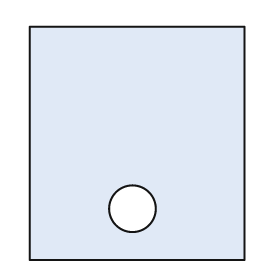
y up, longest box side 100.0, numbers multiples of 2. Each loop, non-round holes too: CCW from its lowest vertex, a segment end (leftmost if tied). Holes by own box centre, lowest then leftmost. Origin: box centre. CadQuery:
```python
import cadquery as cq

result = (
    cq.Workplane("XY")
    .moveTo(-46.0, -50.0)
    .lineTo(46.0, -50.0)
    .lineTo(46.0, 50.0)
    .lineTo(-46.0, 50.0)
    .close()
    .moveTo(-2.0, -28.0)
    .circle(10.0)
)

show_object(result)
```